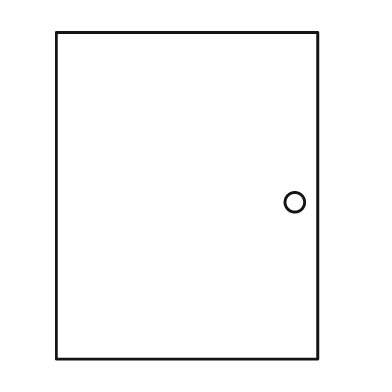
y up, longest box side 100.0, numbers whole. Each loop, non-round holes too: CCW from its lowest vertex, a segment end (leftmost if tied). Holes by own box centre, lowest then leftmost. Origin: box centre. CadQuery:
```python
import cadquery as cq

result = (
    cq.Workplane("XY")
    .moveTo(-40.0, -50.0)
    .lineTo(40.0, -50.0)
    .lineTo(40.0, 50.0)
    .lineTo(-40.0, 50.0)
    .close()
    .moveTo(33.0, -2.0)
    .circle(3.0)
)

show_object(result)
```